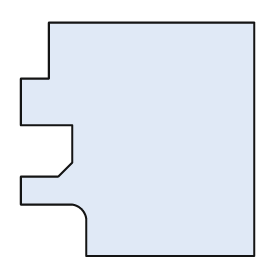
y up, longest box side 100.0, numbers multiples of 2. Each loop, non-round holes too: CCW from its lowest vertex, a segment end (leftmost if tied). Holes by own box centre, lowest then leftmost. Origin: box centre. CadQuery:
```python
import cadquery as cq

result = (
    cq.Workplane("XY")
    .moveTo(-22.0, -50.0)
    .lineTo(50.0, -50.0)
    .lineTo(50.0, 50.0)
    .lineTo(-38.0, 50.0)
    .lineTo(-38.0, 26.0)
    .lineTo(-50.0, 26.0)
    .lineTo(-50.0, 6.0)
    .lineTo(-28.0, 6.0)
    .lineTo(-28.0, -10.0)
    .lineTo(-34.0, -16.0)
    .lineTo(-50.0, -16.0)
    .lineTo(-50.0, -28.0)
    .lineTo(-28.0, -28.0)
    .threePointArc((-24.0, -30.0), (-22.0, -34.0))
    .close()
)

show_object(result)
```